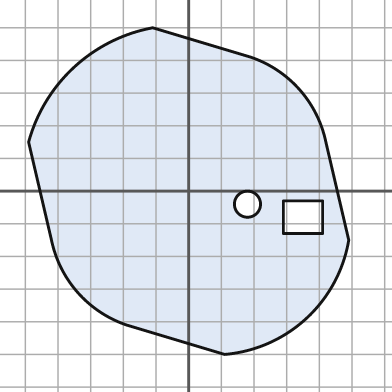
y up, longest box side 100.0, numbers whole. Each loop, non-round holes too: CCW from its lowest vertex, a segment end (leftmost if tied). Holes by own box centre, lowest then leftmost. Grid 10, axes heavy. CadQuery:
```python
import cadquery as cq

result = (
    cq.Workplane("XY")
    .moveTo(11.0, -50.0)
    .threePointArc((36.0, -39.0), (49.0, -15.0))
    .lineTo(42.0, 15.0)
    .threePointArc((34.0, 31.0), (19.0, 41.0))
    .lineTo(-11.0, 50.0)
    .threePointArc((-35.0, 38.0), (-49.0, 15.0))
    .lineTo(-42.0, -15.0)
    .threePointArc((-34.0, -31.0), (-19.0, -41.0))
    .close()
    .moveTo(29.0, -13.0)
    .lineTo(41.0, -13.0)
    .lineTo(41.0, -3.0)
    .lineTo(29.0, -3.0)
    .close()
    .moveTo(18.0, -4.0)
    .circle(4.0)
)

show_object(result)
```